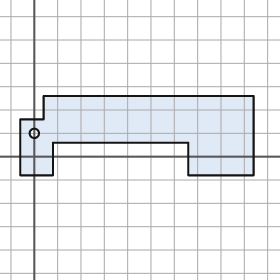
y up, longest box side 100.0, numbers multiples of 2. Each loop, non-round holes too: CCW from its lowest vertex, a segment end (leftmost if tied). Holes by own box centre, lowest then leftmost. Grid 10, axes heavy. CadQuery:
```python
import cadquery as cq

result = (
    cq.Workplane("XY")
    .moveTo(-6.0, -8.0)
    .lineTo(8.0, -8.0)
    .lineTo(8.0, 6.0)
    .lineTo(66.0, 6.0)
    .lineTo(66.0, -8.0)
    .lineTo(94.0, -8.0)
    .lineTo(94.0, 26.0)
    .lineTo(4.0, 26.0)
    .lineTo(4.0, 16.0)
    .lineTo(-6.0, 16.0)
    .close()
    .moveTo(0.0, 10.0)
    .circle(2.0)
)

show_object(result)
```